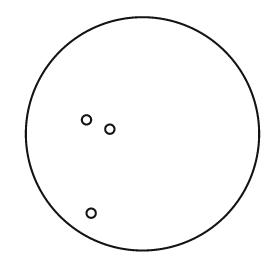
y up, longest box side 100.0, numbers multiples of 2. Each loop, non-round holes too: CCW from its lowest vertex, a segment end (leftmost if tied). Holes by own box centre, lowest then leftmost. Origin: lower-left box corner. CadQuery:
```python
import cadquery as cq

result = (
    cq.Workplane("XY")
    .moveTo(50.0, 50.0)
    .circle(50.0)
    .moveTo(28.0, 16.0)
    .circle(2.0)
    .moveTo(36.0, 52.0)
    .circle(2.0)
    .moveTo(26.0, 56.0)
    .circle(2.0)
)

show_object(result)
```